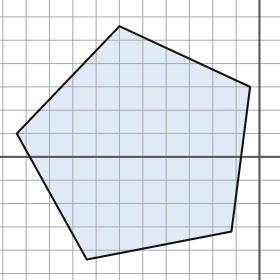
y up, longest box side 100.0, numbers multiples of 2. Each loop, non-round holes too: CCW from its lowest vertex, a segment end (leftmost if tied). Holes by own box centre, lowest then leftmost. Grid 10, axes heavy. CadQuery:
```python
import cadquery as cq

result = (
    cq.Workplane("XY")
    .moveTo(-74.0, -44.0)
    .lineTo(-12.0, -32.0)
    .lineTo(-4.0, 30.0)
    .lineTo(-60.0, 56.0)
    .lineTo(-104.0, 10.0)
    .close()
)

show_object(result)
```